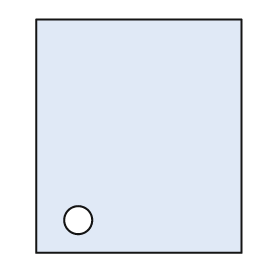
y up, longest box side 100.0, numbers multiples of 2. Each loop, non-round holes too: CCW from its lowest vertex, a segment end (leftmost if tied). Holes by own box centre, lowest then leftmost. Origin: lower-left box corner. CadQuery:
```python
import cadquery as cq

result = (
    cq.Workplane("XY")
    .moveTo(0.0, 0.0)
    .lineTo(88.0, 0.0)
    .lineTo(88.0, 100.0)
    .lineTo(0.0, 100.0)
    .close()
    .moveTo(18.0, 14.0)
    .circle(6.0)
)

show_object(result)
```